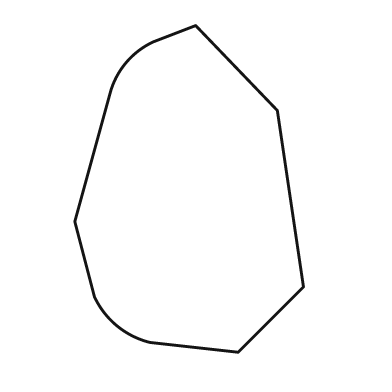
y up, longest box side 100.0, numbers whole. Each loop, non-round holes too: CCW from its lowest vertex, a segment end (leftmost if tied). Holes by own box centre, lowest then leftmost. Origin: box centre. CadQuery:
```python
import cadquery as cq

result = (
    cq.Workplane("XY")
    .moveTo(15.0, -50.0)
    .lineTo(35.0, -30.0)
    .lineTo(27.0, 24.0)
    .lineTo(2.0, 50.0)
    .lineTo(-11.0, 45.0)
    .threePointArc((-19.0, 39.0), (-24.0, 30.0))
    .lineTo(-35.0, -10.0)
    .lineTo(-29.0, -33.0)
    .threePointArc((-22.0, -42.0), (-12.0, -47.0))
    .close()
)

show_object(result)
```